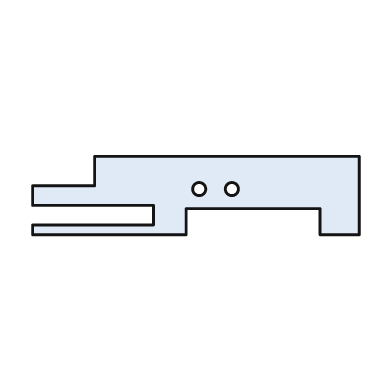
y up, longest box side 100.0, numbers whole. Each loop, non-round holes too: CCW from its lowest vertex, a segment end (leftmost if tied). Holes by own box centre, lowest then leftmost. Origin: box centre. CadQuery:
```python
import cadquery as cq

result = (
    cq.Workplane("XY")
    .moveTo(-50.0, -12.0)
    .lineTo(-3.0, -12.0)
    .lineTo(-3.0, -4.0)
    .lineTo(38.0, -4.0)
    .lineTo(38.0, -12.0)
    .lineTo(50.0, -12.0)
    .lineTo(50.0, 12.0)
    .lineTo(-31.0, 12.0)
    .lineTo(-31.0, 3.0)
    .lineTo(-50.0, 3.0)
    .lineTo(-50.0, -3.0)
    .lineTo(-13.0, -3.0)
    .lineTo(-13.0, -9.0)
    .lineTo(-50.0, -9.0)
    .close()
    .moveTo(1.0, 2.0)
    .circle(2.0)
    .moveTo(11.0, 2.0)
    .circle(2.0)
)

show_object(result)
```